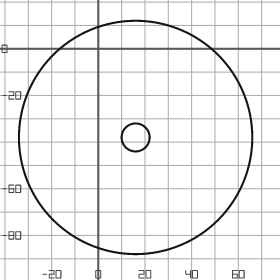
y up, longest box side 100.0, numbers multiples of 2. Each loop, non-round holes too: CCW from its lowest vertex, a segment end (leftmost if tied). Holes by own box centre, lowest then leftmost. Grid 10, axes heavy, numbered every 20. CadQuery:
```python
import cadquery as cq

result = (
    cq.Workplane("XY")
    .moveTo(16.0, -38.0)
    .circle(50.0)
    .moveTo(16.0, -38.0)
    .circle(6.0)
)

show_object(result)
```